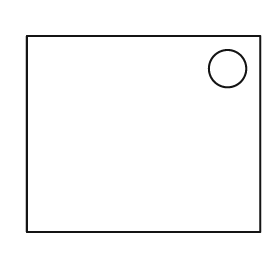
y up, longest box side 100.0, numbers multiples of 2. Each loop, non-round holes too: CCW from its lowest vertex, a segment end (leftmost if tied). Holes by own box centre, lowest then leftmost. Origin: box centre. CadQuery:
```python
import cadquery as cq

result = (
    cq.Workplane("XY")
    .moveTo(-50.0, -42.0)
    .lineTo(50.0, -42.0)
    .lineTo(50.0, 42.0)
    .lineTo(-50.0, 42.0)
    .close()
    .moveTo(36.0, 28.0)
    .circle(8.0)
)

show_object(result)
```